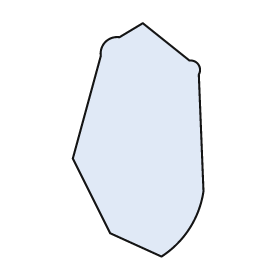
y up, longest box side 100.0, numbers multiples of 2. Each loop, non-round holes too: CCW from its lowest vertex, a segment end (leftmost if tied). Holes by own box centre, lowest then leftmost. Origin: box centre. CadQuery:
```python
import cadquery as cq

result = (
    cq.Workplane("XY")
    .moveTo(10.0, -50.0)
    .threePointArc((22.0, -38.0), (28.0, -22.0))
    .lineTo(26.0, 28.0)
    .threePointArc((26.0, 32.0), (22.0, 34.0))
    .lineTo(2.0, 50.0)
    .lineTo(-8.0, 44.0)
    .threePointArc((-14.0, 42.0), (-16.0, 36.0))
    .lineTo(-28.0, -8.0)
    .lineTo(-12.0, -40.0)
    .close()
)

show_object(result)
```